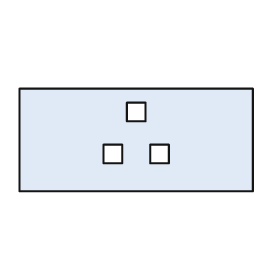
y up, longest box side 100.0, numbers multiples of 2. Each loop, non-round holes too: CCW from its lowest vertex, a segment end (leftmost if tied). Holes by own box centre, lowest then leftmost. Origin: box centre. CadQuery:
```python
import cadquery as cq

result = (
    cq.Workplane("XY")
    .moveTo(-50.0, -22.0)
    .lineTo(50.0, -22.0)
    .lineTo(50.0, 22.0)
    .lineTo(-50.0, 22.0)
    .close()
    .moveTo(-14.0, -10.0)
    .lineTo(-6.0, -10.0)
    .lineTo(-6.0, -2.0)
    .lineTo(-14.0, -2.0)
    .close()
    .moveTo(6.0, -10.0)
    .lineTo(14.0, -10.0)
    .lineTo(14.0, -2.0)
    .lineTo(6.0, -2.0)
    .close()
    .moveTo(-4.0, 8.0)
    .lineTo(4.0, 8.0)
    .lineTo(4.0, 16.0)
    .lineTo(-4.0, 16.0)
    .close()
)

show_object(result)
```